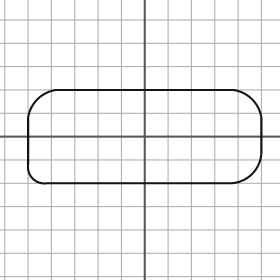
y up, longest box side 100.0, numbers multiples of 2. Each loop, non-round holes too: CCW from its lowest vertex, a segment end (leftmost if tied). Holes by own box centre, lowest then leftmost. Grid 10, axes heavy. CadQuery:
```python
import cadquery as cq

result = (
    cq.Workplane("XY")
    .moveTo(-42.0, -20.0)
    .lineTo(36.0, -20.0)
    .threePointArc((46.0, -16.0), (50.0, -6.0))
    .lineTo(50.0, 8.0)
    .threePointArc((46.0, 16.0), (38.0, 20.0))
    .lineTo(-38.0, 20.0)
    .threePointArc((-46.0, 16.0), (-50.0, 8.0))
    .lineTo(-50.0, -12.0)
    .threePointArc((-48.0, -18.0), (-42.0, -20.0))
    .close()
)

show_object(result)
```